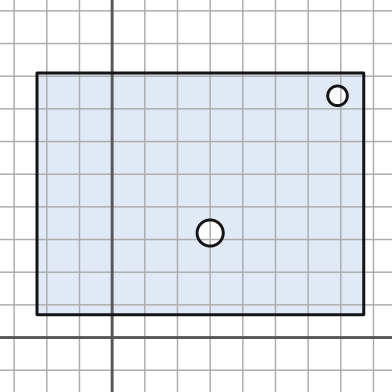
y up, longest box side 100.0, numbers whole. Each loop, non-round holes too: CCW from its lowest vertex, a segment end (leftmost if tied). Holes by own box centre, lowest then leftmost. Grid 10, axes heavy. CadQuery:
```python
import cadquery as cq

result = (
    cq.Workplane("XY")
    .moveTo(-23.0, 7.0)
    .lineTo(77.0, 7.0)
    .lineTo(77.0, 81.0)
    .lineTo(-23.0, 81.0)
    .close()
    .moveTo(30.0, 32.0)
    .circle(4.0)
    .moveTo(69.0, 74.0)
    .circle(3.0)
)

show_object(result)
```